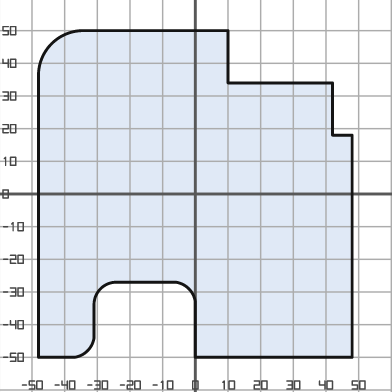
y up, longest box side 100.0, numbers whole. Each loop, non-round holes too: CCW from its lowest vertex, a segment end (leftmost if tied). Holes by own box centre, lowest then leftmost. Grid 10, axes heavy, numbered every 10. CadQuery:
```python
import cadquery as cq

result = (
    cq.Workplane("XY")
    .moveTo(-48.0, -50.0)
    .lineTo(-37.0, -50.0)
    .threePointArc((-33.0, -48.0), (-31.0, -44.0))
    .lineTo(-31.0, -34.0)
    .threePointArc((-29.0, -29.0), (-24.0, -27.0))
    .lineTo(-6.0, -27.0)
    .threePointArc((-2.0, -29.0), (0.0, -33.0))
    .lineTo(0.0, -50.0)
    .lineTo(48.0, -50.0)
    .lineTo(48.0, 18.0)
    .lineTo(42.0, 18.0)
    .lineTo(42.0, 34.0)
    .lineTo(10.0, 34.0)
    .lineTo(10.0, 50.0)
    .lineTo(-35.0, 50.0)
    .threePointArc((-44.0, 46.0), (-48.0, 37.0))
    .close()
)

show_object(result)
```